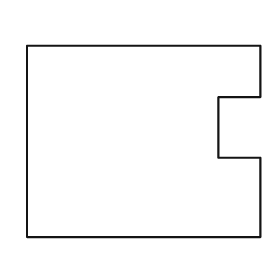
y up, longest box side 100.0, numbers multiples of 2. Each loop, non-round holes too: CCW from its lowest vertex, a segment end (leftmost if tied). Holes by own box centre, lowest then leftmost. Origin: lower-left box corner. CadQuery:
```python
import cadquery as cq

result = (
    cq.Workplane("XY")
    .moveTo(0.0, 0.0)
    .lineTo(100.0, 0.0)
    .lineTo(100.0, 34.0)
    .lineTo(82.0, 34.0)
    .lineTo(82.0, 60.0)
    .lineTo(100.0, 60.0)
    .lineTo(100.0, 82.0)
    .lineTo(0.0, 82.0)
    .close()
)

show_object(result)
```